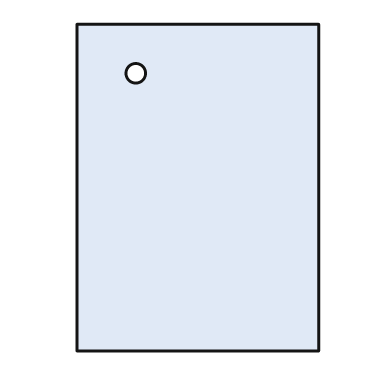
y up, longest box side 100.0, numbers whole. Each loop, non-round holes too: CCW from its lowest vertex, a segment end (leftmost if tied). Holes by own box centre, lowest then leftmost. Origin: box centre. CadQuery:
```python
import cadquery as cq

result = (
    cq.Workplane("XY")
    .moveTo(-37.0, -50.0)
    .lineTo(37.0, -50.0)
    .lineTo(37.0, 50.0)
    .lineTo(-37.0, 50.0)
    .close()
    .moveTo(-19.0, 35.0)
    .circle(3.0)
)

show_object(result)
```